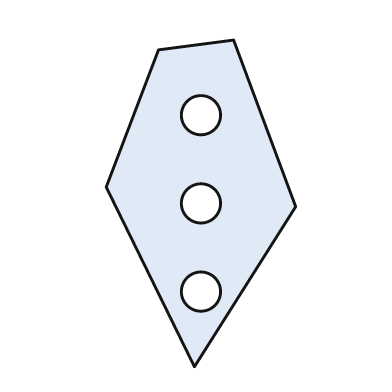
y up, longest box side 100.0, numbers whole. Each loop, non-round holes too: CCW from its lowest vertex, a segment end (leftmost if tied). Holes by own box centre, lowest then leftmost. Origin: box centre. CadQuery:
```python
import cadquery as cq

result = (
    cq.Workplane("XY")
    .moveTo(-2.0, -50.0)
    .lineTo(29.0, -1.0)
    .lineTo(10.0, 50.0)
    .lineTo(-13.0, 47.0)
    .lineTo(-29.0, 5.0)
    .close()
    .moveTo(0.0, -27.0)
    .circle(6.0)
    .moveTo(0.0, 0.0)
    .circle(6.0)
    .moveTo(0.0, 27.0)
    .circle(6.0)
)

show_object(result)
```